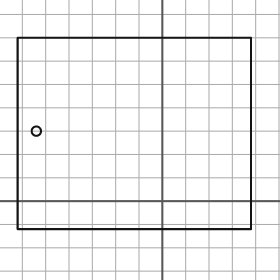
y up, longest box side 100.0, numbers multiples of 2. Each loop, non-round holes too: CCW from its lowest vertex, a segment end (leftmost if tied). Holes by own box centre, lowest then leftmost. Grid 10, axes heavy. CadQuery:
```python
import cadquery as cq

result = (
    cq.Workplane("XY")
    .moveTo(-62.0, -12.0)
    .lineTo(38.0, -12.0)
    .lineTo(38.0, 70.0)
    .lineTo(-62.0, 70.0)
    .close()
    .moveTo(-54.0, 30.0)
    .circle(2.0)
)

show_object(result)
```